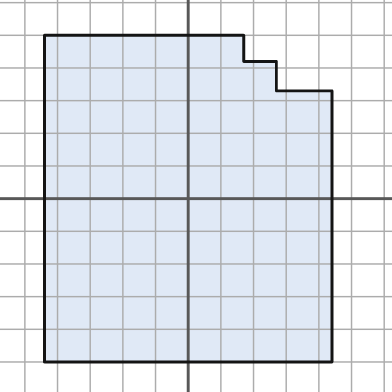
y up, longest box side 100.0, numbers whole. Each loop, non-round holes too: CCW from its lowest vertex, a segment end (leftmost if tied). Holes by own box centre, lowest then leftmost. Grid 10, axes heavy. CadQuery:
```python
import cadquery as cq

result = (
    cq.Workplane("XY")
    .moveTo(-44.0, -50.0)
    .lineTo(44.0, -50.0)
    .lineTo(44.0, 33.0)
    .lineTo(27.0, 33.0)
    .lineTo(27.0, 42.0)
    .lineTo(17.0, 42.0)
    .lineTo(17.0, 50.0)
    .lineTo(-44.0, 50.0)
    .close()
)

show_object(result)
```